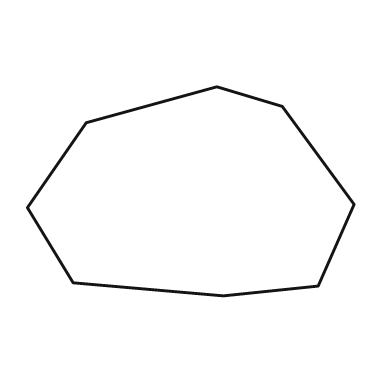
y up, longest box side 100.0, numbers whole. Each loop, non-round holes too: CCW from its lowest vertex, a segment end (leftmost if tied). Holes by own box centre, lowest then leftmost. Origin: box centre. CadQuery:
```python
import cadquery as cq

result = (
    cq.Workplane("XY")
    .moveTo(10.0, -32.0)
    .lineTo(39.0, -29.0)
    .lineTo(50.0, -4.0)
    .lineTo(28.0, 26.0)
    .lineTo(8.0, 32.0)
    .lineTo(-32.0, 21.0)
    .lineTo(-50.0, -5.0)
    .lineTo(-36.0, -28.0)
    .close()
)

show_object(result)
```